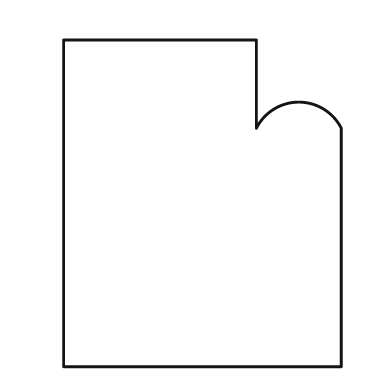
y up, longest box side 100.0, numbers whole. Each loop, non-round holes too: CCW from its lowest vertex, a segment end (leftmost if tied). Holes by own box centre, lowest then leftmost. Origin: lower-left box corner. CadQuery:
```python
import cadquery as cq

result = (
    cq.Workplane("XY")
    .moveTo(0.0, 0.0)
    .lineTo(85.0, 0.0)
    .lineTo(85.0, 73.0)
    .threePointArc((72.0, 81.0), (59.0, 73.0))
    .lineTo(59.0, 100.0)
    .lineTo(0.0, 100.0)
    .close()
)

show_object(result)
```